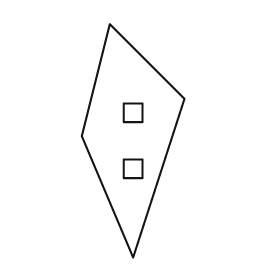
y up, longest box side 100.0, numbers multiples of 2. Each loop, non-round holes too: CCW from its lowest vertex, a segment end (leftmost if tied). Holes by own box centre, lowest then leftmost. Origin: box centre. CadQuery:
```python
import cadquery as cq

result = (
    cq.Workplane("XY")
    .moveTo(0.0, -50.0)
    .lineTo(22.0, 18.0)
    .lineTo(-10.0, 50.0)
    .lineTo(-22.0, 2.0)
    .close()
    .moveTo(-4.0, -16.0)
    .lineTo(4.0, -16.0)
    .lineTo(4.0, -8.0)
    .lineTo(-4.0, -8.0)
    .close()
    .moveTo(-4.0, 8.0)
    .lineTo(4.0, 8.0)
    .lineTo(4.0, 16.0)
    .lineTo(-4.0, 16.0)
    .close()
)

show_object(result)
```